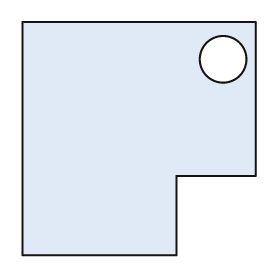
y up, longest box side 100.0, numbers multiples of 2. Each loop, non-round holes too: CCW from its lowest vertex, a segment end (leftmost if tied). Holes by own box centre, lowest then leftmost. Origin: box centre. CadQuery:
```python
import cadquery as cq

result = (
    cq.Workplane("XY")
    .moveTo(-50.0, -50.0)
    .lineTo(16.0, -50.0)
    .lineTo(16.0, -16.0)
    .lineTo(50.0, -16.0)
    .lineTo(50.0, 50.0)
    .lineTo(-50.0, 50.0)
    .close()
    .moveTo(36.0, 34.0)
    .circle(10.0)
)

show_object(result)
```